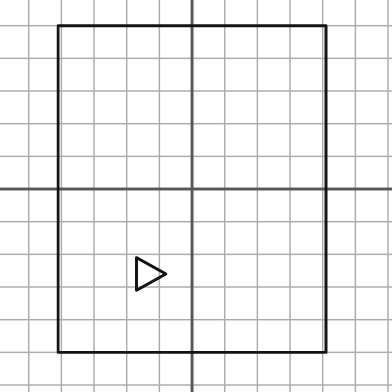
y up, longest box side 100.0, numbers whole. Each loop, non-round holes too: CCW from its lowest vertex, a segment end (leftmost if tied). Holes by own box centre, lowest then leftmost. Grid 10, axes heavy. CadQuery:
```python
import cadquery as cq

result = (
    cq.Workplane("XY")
    .moveTo(-41.0, -50.0)
    .lineTo(41.0, -50.0)
    .lineTo(41.0, 50.0)
    .lineTo(-41.0, 50.0)
    .close()
    .moveTo(-17.0, -31.0)
    .lineTo(-8.0, -26.0)
    .lineTo(-17.0, -21.0)
    .close()
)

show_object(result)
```